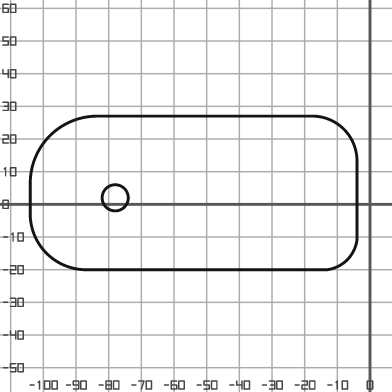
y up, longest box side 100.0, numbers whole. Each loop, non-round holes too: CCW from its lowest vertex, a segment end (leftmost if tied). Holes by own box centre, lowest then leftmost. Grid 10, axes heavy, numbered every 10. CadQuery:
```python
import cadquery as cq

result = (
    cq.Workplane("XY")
    .moveTo(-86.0, -20.0)
    .lineTo(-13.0, -20.0)
    .threePointArc((-7.0, -17.0), (-4.0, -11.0))
    .lineTo(-4.0, 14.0)
    .threePointArc((-8.0, 23.0), (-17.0, 27.0))
    .lineTo(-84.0, 27.0)
    .threePointArc((-98.0, 21.0), (-104.0, 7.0))
    .lineTo(-104.0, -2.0)
    .threePointArc((-99.0, -15.0), (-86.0, -20.0))
    .close()
    .moveTo(-78.0, 2.0)
    .circle(4.0)
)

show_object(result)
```